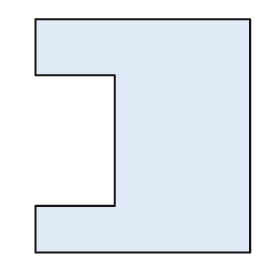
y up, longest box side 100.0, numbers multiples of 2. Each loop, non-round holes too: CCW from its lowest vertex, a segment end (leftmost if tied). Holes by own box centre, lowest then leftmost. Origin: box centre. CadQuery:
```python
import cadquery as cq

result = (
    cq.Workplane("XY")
    .moveTo(-46.0, -50.0)
    .lineTo(46.0, -50.0)
    .lineTo(46.0, 50.0)
    .lineTo(-46.0, 50.0)
    .lineTo(-46.0, 26.0)
    .lineTo(-12.0, 26.0)
    .lineTo(-12.0, -30.0)
    .lineTo(-46.0, -30.0)
    .close()
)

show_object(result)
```